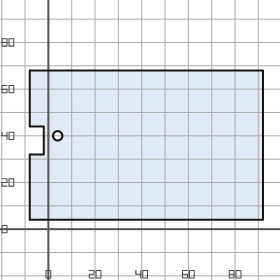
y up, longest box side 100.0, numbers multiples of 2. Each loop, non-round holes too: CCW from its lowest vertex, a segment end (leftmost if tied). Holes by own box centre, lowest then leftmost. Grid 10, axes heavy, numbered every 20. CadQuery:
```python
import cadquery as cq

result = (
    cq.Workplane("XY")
    .moveTo(-8.0, 4.0)
    .lineTo(92.0, 4.0)
    .lineTo(92.0, 68.0)
    .lineTo(-8.0, 68.0)
    .lineTo(-8.0, 44.0)
    .lineTo(-2.0, 44.0)
    .lineTo(-2.0, 32.0)
    .lineTo(-8.0, 32.0)
    .close()
    .moveTo(4.0, 40.0)
    .circle(2.0)
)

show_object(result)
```